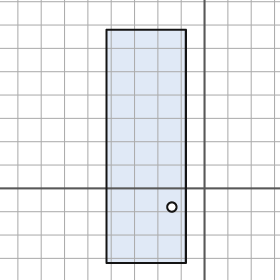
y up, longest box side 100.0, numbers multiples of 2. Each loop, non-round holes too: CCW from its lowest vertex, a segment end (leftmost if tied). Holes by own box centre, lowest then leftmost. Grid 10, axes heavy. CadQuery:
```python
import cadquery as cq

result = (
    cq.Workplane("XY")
    .moveTo(-42.0, -32.0)
    .lineTo(-8.0, -32.0)
    .lineTo(-8.0, 68.0)
    .lineTo(-42.0, 68.0)
    .close()
    .moveTo(-14.0, -8.0)
    .circle(2.0)
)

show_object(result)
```